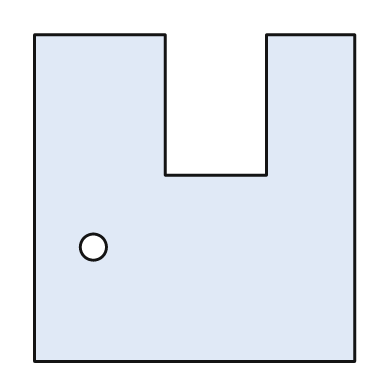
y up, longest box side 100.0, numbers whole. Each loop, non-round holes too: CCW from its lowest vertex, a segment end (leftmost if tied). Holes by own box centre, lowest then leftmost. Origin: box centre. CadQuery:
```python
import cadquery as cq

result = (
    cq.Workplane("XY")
    .moveTo(-49.0, -50.0)
    .lineTo(49.0, -50.0)
    .lineTo(49.0, 50.0)
    .lineTo(22.0, 50.0)
    .lineTo(22.0, 7.0)
    .lineTo(-9.0, 7.0)
    .lineTo(-9.0, 50.0)
    .lineTo(-49.0, 50.0)
    .close()
    .moveTo(-31.0, -15.0)
    .circle(4.0)
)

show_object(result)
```